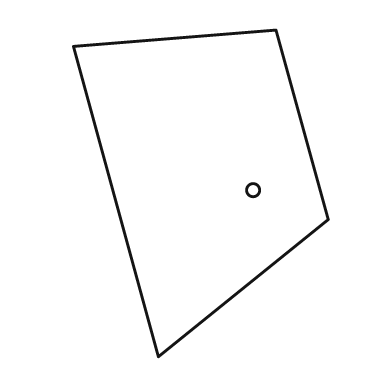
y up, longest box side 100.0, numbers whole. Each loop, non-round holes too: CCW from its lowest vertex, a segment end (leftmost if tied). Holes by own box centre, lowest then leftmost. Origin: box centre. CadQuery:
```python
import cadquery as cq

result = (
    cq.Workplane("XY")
    .moveTo(-13.0, -50.0)
    .lineTo(39.0, -8.0)
    .lineTo(23.0, 50.0)
    .lineTo(-39.0, 45.0)
    .close()
    .moveTo(16.0, 1.0)
    .circle(2.0)
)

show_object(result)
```